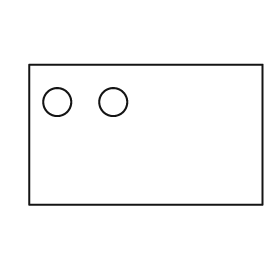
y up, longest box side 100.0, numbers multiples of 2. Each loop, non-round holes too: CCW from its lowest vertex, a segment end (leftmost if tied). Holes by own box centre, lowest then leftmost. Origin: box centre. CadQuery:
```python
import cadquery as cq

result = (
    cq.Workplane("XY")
    .moveTo(-50.0, -30.0)
    .lineTo(50.0, -30.0)
    .lineTo(50.0, 30.0)
    .lineTo(-50.0, 30.0)
    .close()
    .moveTo(-38.0, 14.0)
    .circle(6.0)
    .moveTo(-14.0, 14.0)
    .circle(6.0)
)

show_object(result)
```